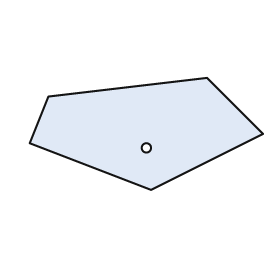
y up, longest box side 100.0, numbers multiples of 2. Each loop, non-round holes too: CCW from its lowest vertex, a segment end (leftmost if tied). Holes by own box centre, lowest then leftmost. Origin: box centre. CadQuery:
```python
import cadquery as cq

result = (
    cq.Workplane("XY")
    .moveTo(2.0, -24.0)
    .lineTo(50.0, 0.0)
    .lineTo(26.0, 24.0)
    .lineTo(-42.0, 16.0)
    .lineTo(-50.0, -4.0)
    .close()
    .moveTo(0.0, -6.0)
    .circle(2.0)
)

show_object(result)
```